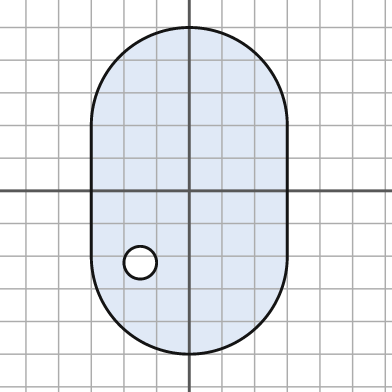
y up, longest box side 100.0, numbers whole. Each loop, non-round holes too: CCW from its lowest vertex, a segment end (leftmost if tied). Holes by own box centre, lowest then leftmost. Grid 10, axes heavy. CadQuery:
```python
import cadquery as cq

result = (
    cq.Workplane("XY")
    .moveTo(-30.0, -20.0)
    .threePointArc((0.0, -50.0), (30.0, -20.0))
    .lineTo(30.0, 20.0)
    .threePointArc((0.0, 50.0), (-30.0, 20.0))
    .close()
    .moveTo(-15.0, -22.0)
    .circle(5.0)
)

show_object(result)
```